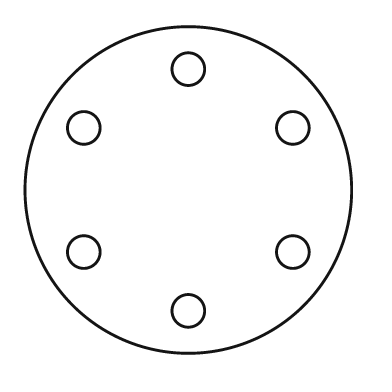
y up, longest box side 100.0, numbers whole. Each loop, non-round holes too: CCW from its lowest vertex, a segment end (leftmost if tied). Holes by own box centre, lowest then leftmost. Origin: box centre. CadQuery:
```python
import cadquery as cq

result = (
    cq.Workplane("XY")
    .moveTo(0.0, 0.0)
    .circle(50.0)
    .moveTo(0.0, -37.0)
    .circle(5.0)
    .moveTo(-32.0, -19.0)
    .circle(5.0)
    .moveTo(32.0, -19.0)
    .circle(5.0)
    .moveTo(-32.0, 19.0)
    .circle(5.0)
    .moveTo(32.0, 19.0)
    .circle(5.0)
    .moveTo(0.0, 37.0)
    .circle(5.0)
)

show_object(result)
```